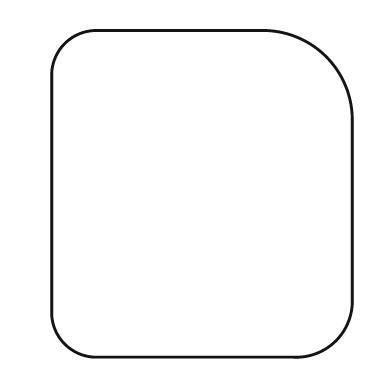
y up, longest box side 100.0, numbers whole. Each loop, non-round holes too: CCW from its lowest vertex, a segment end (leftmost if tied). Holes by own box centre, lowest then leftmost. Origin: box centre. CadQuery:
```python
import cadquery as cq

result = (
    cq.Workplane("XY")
    .moveTo(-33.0, -50.0)
    .lineTo(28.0, -50.0)
    .threePointArc((41.0, -45.0), (46.0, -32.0))
    .lineTo(46.0, 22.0)
    .threePointArc((38.0, 42.0), (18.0, 50.0))
    .lineTo(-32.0, 50.0)
    .threePointArc((-42.0, 46.0), (-46.0, 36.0))
    .lineTo(-46.0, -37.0)
    .threePointArc((-42.0, -46.0), (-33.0, -50.0))
    .close()
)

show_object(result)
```